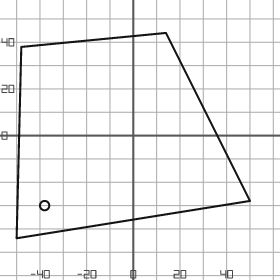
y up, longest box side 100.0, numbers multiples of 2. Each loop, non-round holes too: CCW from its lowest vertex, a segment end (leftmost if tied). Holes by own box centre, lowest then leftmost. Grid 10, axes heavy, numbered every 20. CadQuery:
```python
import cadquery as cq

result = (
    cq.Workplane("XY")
    .moveTo(-50.0, -44.0)
    .lineTo(50.0, -28.0)
    .lineTo(14.0, 44.0)
    .lineTo(-48.0, 38.0)
    .close()
    .moveTo(-38.0, -30.0)
    .circle(2.0)
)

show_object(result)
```